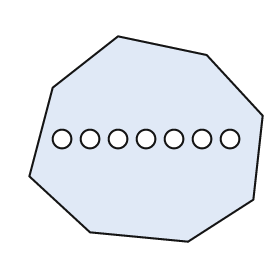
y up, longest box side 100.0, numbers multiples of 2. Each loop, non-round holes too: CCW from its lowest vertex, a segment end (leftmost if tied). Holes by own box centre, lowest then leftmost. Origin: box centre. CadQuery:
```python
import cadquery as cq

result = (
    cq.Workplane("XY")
    .moveTo(18.0, -44.0)
    .lineTo(46.0, -26.0)
    .lineTo(50.0, 10.0)
    .lineTo(26.0, 36.0)
    .lineTo(-12.0, 44.0)
    .lineTo(-40.0, 22.0)
    .lineTo(-50.0, -16.0)
    .lineTo(-24.0, -40.0)
    .close()
    .moveTo(-36.0, 0.0)
    .circle(4.0)
    .moveTo(-24.0, 0.0)
    .circle(4.0)
    .moveTo(-12.0, 0.0)
    .circle(4.0)
    .moveTo(0.0, 0.0)
    .circle(4.0)
    .moveTo(12.0, 0.0)
    .circle(4.0)
    .moveTo(24.0, 0.0)
    .circle(4.0)
    .moveTo(36.0, 0.0)
    .circle(4.0)
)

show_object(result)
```